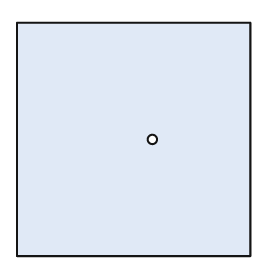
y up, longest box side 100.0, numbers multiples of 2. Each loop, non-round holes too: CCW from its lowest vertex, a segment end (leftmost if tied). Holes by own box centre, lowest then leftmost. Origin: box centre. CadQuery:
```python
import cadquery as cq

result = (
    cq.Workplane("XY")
    .moveTo(-50.0, -50.0)
    .lineTo(50.0, -50.0)
    .lineTo(50.0, 50.0)
    .lineTo(-50.0, 50.0)
    .close()
    .moveTo(8.0, 0.0)
    .circle(2.0)
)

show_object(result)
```